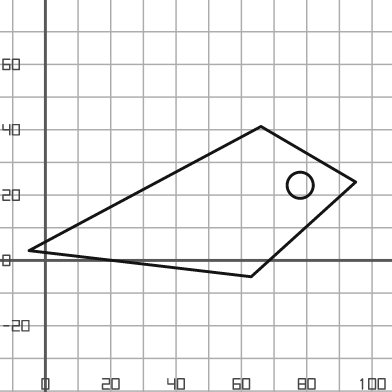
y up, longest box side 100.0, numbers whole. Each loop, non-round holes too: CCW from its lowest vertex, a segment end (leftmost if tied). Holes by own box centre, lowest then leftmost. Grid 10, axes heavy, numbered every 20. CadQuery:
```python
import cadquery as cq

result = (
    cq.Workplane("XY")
    .moveTo(63.0, -5.0)
    .lineTo(95.0, 24.0)
    .lineTo(66.0, 41.0)
    .lineTo(-5.0, 3.0)
    .close()
    .moveTo(78.0, 23.0)
    .circle(4.0)
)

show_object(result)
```